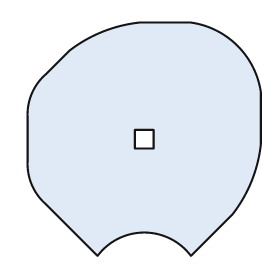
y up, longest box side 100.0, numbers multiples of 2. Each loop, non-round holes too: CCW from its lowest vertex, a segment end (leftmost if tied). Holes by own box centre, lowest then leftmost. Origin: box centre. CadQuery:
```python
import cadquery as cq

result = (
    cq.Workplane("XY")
    .moveTo(-20.0, -50.0)
    .threePointArc((0.0, -40.0), (20.0, -50.0))
    .lineTo(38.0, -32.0)
    .threePointArc((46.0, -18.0), (50.0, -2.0))
    .lineTo(50.0, 20.0)
    .threePointArc((40.0, 40.0), (20.0, 50.0))
    .lineTo(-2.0, 50.0)
    .threePointArc((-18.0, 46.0), (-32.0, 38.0))
    .lineTo(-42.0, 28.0)
    .threePointArc((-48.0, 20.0), (-50.0, 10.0))
    .lineTo(-50.0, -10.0)
    .threePointArc((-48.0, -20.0), (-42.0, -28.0))
    .close()
    .moveTo(-4.0, -4.0)
    .lineTo(4.0, -4.0)
    .lineTo(4.0, 4.0)
    .lineTo(-4.0, 4.0)
    .close()
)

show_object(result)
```